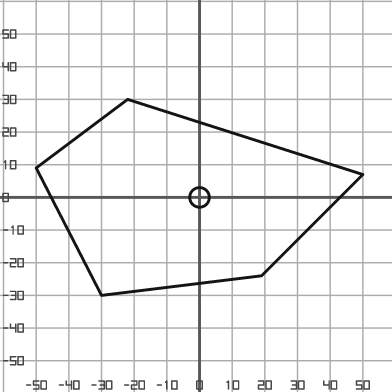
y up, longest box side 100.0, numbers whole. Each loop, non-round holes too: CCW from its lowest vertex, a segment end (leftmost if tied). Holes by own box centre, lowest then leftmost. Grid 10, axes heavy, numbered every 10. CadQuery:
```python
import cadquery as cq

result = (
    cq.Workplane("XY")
    .moveTo(-30.0, -30.0)
    .lineTo(19.0, -24.0)
    .lineTo(50.0, 7.0)
    .lineTo(-22.0, 30.0)
    .lineTo(-50.0, 9.0)
    .close()
    .moveTo(0.0, 0.0)
    .circle(3.0)
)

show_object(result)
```